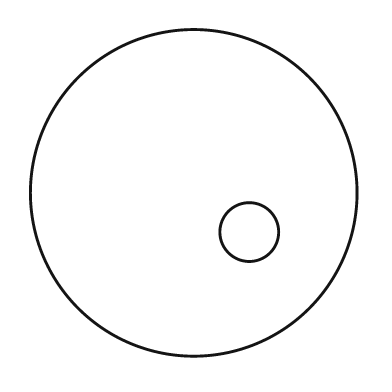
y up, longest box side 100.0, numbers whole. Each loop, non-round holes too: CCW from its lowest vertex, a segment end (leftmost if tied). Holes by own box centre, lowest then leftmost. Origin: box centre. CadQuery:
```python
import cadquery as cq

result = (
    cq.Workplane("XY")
    .moveTo(0.0, 0.0)
    .circle(50.0)
    .moveTo(17.0, -12.0)
    .circle(9.0)
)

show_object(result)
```